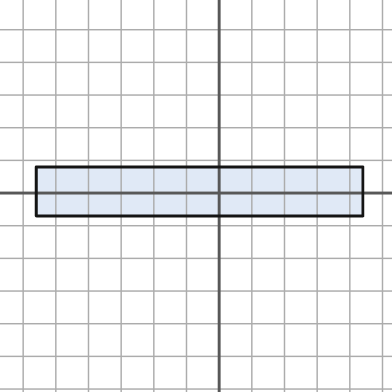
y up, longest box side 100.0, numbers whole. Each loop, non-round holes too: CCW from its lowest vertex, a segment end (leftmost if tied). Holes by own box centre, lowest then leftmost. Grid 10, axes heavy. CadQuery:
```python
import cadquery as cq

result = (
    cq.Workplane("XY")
    .moveTo(-56.0, -7.0)
    .lineTo(44.0, -7.0)
    .lineTo(44.0, 8.0)
    .lineTo(-56.0, 8.0)
    .close()
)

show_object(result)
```